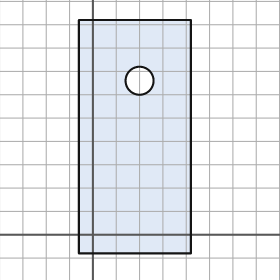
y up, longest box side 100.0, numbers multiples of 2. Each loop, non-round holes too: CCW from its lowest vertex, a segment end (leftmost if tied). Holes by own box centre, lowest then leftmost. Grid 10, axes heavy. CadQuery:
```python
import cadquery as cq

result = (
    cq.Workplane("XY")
    .moveTo(-6.0, -8.0)
    .lineTo(42.0, -8.0)
    .lineTo(42.0, 92.0)
    .lineTo(-6.0, 92.0)
    .close()
    .moveTo(20.0, 66.0)
    .circle(6.0)
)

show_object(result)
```